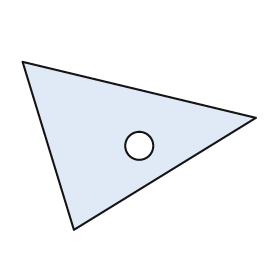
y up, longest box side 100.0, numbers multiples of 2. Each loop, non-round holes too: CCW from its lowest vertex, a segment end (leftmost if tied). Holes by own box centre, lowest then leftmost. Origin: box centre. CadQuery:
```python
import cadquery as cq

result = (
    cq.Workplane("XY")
    .moveTo(-28.0, -36.0)
    .lineTo(50.0, 12.0)
    .lineTo(-50.0, 36.0)
    .close()
    .moveTo(0.0, 0.0)
    .circle(6.0)
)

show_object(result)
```